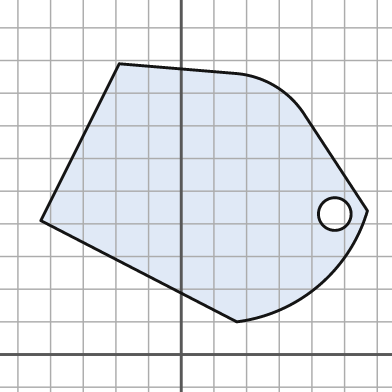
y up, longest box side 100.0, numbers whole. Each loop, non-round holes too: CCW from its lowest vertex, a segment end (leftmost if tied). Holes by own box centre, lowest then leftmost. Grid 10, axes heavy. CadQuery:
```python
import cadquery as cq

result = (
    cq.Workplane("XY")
    .moveTo(17.0, 10.0)
    .threePointArc((42.0, 21.0), (57.0, 44.0))
    .lineTo(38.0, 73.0)
    .threePointArc((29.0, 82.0), (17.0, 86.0))
    .lineTo(-19.0, 89.0)
    .lineTo(-43.0, 41.0)
    .close()
    .moveTo(47.0, 43.0)
    .circle(5.0)
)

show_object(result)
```